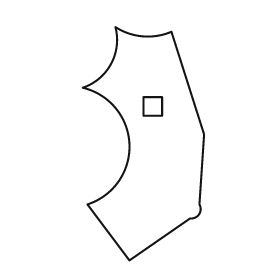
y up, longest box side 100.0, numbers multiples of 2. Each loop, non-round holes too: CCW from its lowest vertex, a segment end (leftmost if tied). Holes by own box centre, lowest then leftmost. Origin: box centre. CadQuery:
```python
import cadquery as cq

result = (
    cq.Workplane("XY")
    .moveTo(-6.0, -50.0)
    .lineTo(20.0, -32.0)
    .threePointArc((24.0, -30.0), (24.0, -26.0))
    .lineTo(26.0, 4.0)
    .lineTo(12.0, 48.0)
    .threePointArc((0.0, 46.0), (-12.0, 50.0))
    .threePointArc((-14.0, 34.0), (-26.0, 24.0))
    .threePointArc((-6.0, 0.0), (-24.0, -26.0))
    .close()
    .moveTo(0.0, 12.0)
    .lineTo(8.0, 12.0)
    .lineTo(8.0, 20.0)
    .lineTo(0.0, 20.0)
    .close()
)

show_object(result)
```